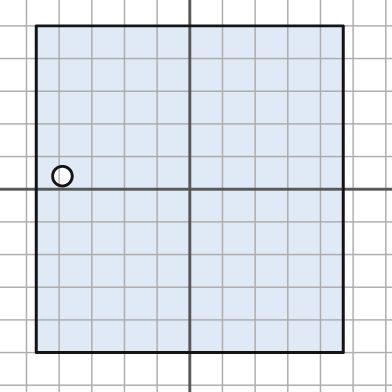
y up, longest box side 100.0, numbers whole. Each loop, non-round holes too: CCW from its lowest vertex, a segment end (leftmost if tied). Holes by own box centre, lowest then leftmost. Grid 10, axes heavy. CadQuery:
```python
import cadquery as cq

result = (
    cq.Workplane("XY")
    .moveTo(-47.0, -50.0)
    .lineTo(47.0, -50.0)
    .lineTo(47.0, 50.0)
    .lineTo(-47.0, 50.0)
    .close()
    .moveTo(-39.0, 4.0)
    .circle(3.0)
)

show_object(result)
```